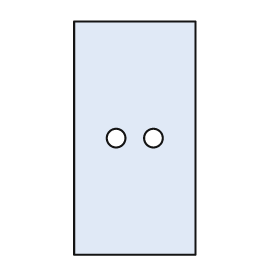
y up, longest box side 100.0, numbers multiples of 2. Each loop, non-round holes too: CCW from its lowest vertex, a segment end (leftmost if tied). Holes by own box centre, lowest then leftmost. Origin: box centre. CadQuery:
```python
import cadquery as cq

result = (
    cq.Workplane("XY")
    .moveTo(-26.0, -50.0)
    .lineTo(26.0, -50.0)
    .lineTo(26.0, 50.0)
    .lineTo(-26.0, 50.0)
    .close()
    .moveTo(-8.0, 0.0)
    .circle(4.0)
    .moveTo(8.0, 0.0)
    .circle(4.0)
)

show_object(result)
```